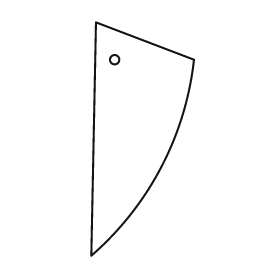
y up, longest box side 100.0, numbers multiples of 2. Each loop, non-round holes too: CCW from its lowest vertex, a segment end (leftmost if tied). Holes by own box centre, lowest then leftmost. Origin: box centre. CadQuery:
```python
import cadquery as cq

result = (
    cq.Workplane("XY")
    .moveTo(-22.0, -50.0)
    .threePointArc((8.0, -12.0), (22.0, 34.0))
    .lineTo(-20.0, 50.0)
    .close()
    .moveTo(-12.0, 34.0)
    .circle(2.0)
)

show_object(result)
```